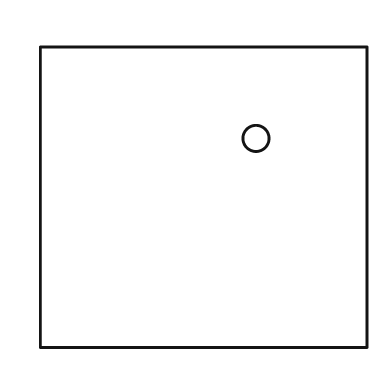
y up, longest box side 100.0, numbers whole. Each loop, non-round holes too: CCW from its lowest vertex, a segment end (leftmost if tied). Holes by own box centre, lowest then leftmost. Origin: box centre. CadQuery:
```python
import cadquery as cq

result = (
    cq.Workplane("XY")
    .moveTo(-50.0, -46.0)
    .lineTo(50.0, -46.0)
    .lineTo(50.0, 46.0)
    .lineTo(-50.0, 46.0)
    .close()
    .moveTo(16.0, 18.0)
    .circle(4.0)
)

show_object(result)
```